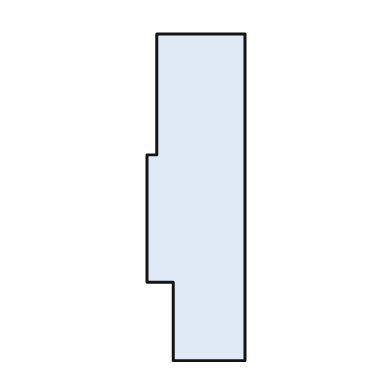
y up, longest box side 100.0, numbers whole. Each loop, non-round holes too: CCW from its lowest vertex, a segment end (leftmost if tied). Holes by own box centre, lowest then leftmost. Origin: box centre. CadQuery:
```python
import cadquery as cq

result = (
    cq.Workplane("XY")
    .moveTo(-7.0, -50.0)
    .lineTo(15.0, -50.0)
    .lineTo(15.0, 50.0)
    .lineTo(-12.0, 50.0)
    .lineTo(-12.0, 13.0)
    .lineTo(-15.0, 13.0)
    .lineTo(-15.0, -26.0)
    .lineTo(-7.0, -26.0)
    .close()
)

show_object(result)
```